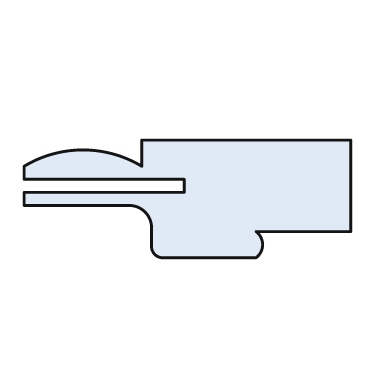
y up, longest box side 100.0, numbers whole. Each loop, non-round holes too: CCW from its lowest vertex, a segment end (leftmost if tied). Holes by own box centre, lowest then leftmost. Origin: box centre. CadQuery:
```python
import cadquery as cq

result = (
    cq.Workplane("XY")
    .moveTo(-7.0, -18.0)
    .lineTo(21.0, -18.0)
    .threePointArc((23.0, -14.0), (21.0, -10.0))
    .lineTo(50.0, -10.0)
    .lineTo(50.0, 18.0)
    .lineTo(-14.0, 18.0)
    .lineTo(-14.0, 10.0)
    .threePointArc((-32.0, 15.0), (-50.0, 10.0))
    .lineTo(-50.0, 6.0)
    .lineTo(-1.0, 6.0)
    .lineTo(-1.0, 2.0)
    .lineTo(-50.0, 2.0)
    .lineTo(-50.0, -2.0)
    .lineTo(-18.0, -2.0)
    .threePointArc((-13.0, -4.0), (-11.0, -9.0))
    .lineTo(-11.0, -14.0)
    .threePointArc((-10.0, -17.0), (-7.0, -18.0))
    .close()
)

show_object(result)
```